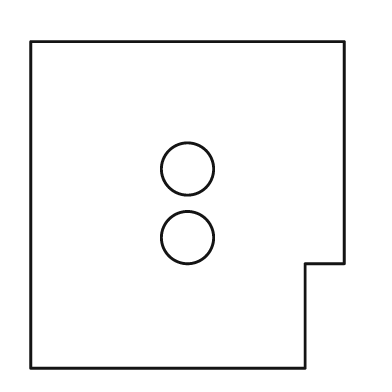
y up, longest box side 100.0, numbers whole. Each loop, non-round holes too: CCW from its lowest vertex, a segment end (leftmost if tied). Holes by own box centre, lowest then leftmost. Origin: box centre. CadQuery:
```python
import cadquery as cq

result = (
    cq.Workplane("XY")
    .moveTo(-48.0, -50.0)
    .lineTo(36.0, -50.0)
    .lineTo(36.0, -18.0)
    .lineTo(48.0, -18.0)
    .lineTo(48.0, 50.0)
    .lineTo(-48.0, 50.0)
    .close()
    .moveTo(0.0, -10.0)
    .circle(8.0)
    .moveTo(0.0, 11.0)
    .circle(8.0)
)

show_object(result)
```